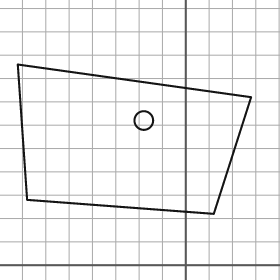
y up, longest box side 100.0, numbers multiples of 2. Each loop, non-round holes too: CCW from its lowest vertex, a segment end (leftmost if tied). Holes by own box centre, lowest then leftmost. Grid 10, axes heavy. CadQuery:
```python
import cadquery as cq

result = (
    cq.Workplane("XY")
    .moveTo(12.0, 22.0)
    .lineTo(28.0, 72.0)
    .lineTo(-72.0, 86.0)
    .lineTo(-68.0, 28.0)
    .close()
    .moveTo(-18.0, 62.0)
    .circle(4.0)
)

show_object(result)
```